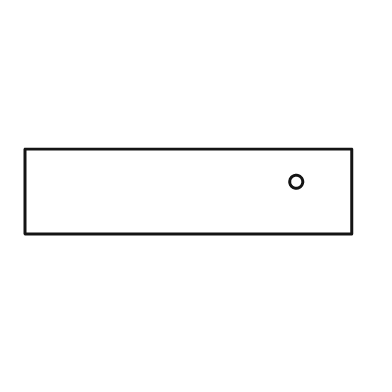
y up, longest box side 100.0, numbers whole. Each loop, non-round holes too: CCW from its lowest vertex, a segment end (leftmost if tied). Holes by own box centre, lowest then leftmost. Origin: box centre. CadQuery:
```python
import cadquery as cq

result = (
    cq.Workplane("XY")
    .moveTo(-50.0, -13.0)
    .lineTo(50.0, -13.0)
    .lineTo(50.0, 13.0)
    .lineTo(-50.0, 13.0)
    .close()
    .moveTo(33.0, 3.0)
    .circle(2.0)
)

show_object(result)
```